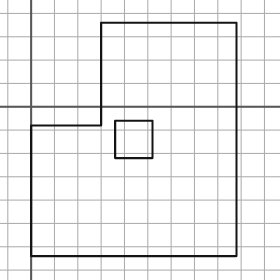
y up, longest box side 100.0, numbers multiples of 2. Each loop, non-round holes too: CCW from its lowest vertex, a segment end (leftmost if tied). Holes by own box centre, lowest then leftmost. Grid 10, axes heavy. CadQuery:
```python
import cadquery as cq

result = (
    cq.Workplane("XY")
    .moveTo(0.0, -64.0)
    .lineTo(88.0, -64.0)
    .lineTo(88.0, 36.0)
    .lineTo(30.0, 36.0)
    .lineTo(30.0, -8.0)
    .lineTo(0.0, -8.0)
    .close()
    .moveTo(36.0, -22.0)
    .lineTo(52.0, -22.0)
    .lineTo(52.0, -6.0)
    .lineTo(36.0, -6.0)
    .close()
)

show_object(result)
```